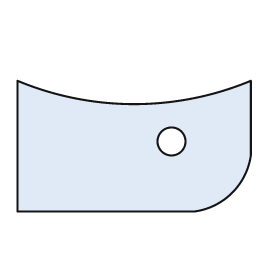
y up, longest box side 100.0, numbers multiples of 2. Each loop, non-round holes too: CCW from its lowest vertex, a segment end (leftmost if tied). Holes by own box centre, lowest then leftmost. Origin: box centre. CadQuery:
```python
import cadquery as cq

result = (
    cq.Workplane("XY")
    .moveTo(-50.0, -28.0)
    .lineTo(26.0, -28.0)
    .threePointArc((42.0, -20.0), (50.0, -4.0))
    .lineTo(50.0, 28.0)
    .threePointArc((0.0, 18.0), (-50.0, 28.0))
    .close()
    .moveTo(16.0, 2.0)
    .circle(6.0)
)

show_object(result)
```